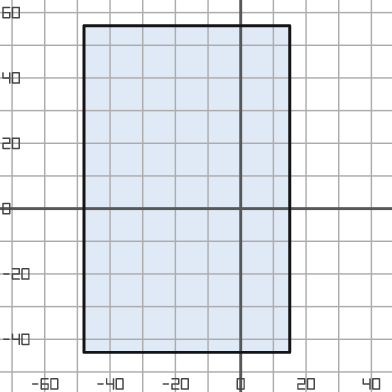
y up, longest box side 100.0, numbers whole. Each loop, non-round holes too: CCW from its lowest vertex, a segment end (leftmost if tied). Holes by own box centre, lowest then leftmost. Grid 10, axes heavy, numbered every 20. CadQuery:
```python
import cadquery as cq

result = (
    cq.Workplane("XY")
    .moveTo(-48.0, -44.0)
    .lineTo(15.0, -44.0)
    .lineTo(15.0, 56.0)
    .lineTo(-48.0, 56.0)
    .close()
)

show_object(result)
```